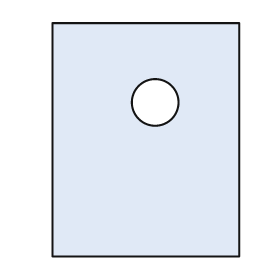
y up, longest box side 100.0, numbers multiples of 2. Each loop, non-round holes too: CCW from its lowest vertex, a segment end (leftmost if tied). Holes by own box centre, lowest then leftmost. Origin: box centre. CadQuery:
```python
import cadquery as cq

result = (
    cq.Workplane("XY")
    .moveTo(-40.0, -50.0)
    .lineTo(40.0, -50.0)
    .lineTo(40.0, 50.0)
    .lineTo(-40.0, 50.0)
    .close()
    .moveTo(4.0, 16.0)
    .circle(10.0)
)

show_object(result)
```